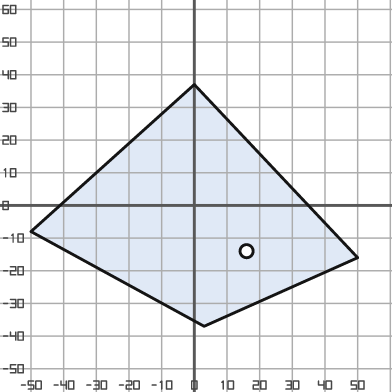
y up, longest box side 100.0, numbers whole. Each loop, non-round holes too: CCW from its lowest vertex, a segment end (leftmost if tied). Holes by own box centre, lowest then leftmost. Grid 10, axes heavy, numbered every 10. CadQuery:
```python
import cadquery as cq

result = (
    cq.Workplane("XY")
    .moveTo(3.0, -37.0)
    .lineTo(50.0, -16.0)
    .lineTo(0.0, 37.0)
    .lineTo(-50.0, -8.0)
    .close()
    .moveTo(16.0, -14.0)
    .circle(2.0)
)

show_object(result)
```